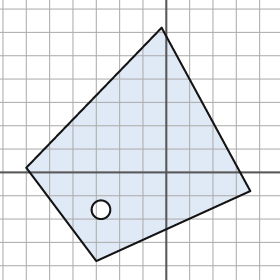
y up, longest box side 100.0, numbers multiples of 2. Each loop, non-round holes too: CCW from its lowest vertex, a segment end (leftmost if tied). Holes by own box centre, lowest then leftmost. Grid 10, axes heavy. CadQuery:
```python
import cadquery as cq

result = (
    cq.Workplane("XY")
    .moveTo(-30.0, -38.0)
    .lineTo(36.0, -8.0)
    .lineTo(-2.0, 62.0)
    .lineTo(-60.0, 2.0)
    .close()
    .moveTo(-28.0, -16.0)
    .circle(4.0)
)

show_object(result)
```